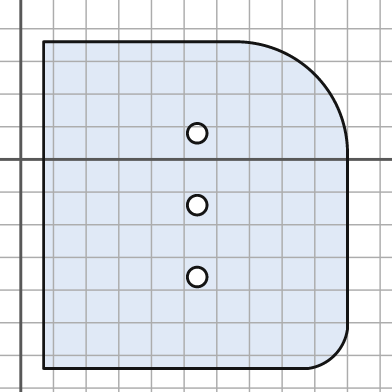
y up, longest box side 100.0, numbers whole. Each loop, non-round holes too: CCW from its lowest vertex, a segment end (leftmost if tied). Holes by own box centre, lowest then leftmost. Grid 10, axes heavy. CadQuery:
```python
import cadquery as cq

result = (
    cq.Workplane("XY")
    .moveTo(7.0, -64.0)
    .lineTo(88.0, -64.0)
    .threePointArc((96.0, -60.0), (100.0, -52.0))
    .lineTo(100.0, 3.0)
    .threePointArc((90.0, 26.0), (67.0, 36.0))
    .lineTo(7.0, 36.0)
    .close()
    .moveTo(54.0, -36.0)
    .circle(3.0)
    .moveTo(54.0, -14.0)
    .circle(3.0)
    .moveTo(54.0, 8.0)
    .circle(3.0)
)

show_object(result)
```